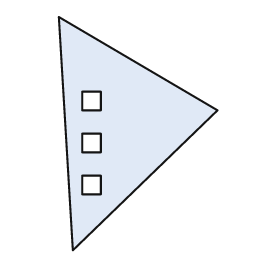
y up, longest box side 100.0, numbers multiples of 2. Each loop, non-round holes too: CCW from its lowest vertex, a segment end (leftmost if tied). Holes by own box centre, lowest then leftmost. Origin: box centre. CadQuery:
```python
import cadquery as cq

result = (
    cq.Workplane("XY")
    .moveTo(-28.0, -50.0)
    .lineTo(34.0, 10.0)
    .lineTo(-34.0, 50.0)
    .close()
    .moveTo(-24.0, -26.0)
    .lineTo(-16.0, -26.0)
    .lineTo(-16.0, -18.0)
    .lineTo(-24.0, -18.0)
    .close()
    .moveTo(-24.0, -8.0)
    .lineTo(-16.0, -8.0)
    .lineTo(-16.0, 0.0)
    .lineTo(-24.0, 0.0)
    .close()
    .moveTo(-24.0, 10.0)
    .lineTo(-16.0, 10.0)
    .lineTo(-16.0, 18.0)
    .lineTo(-24.0, 18.0)
    .close()
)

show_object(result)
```